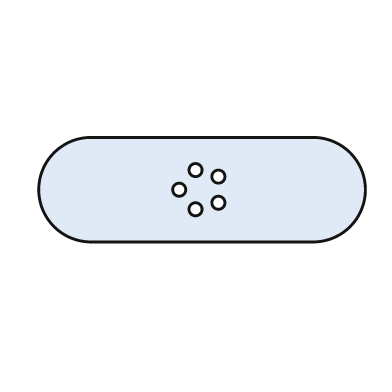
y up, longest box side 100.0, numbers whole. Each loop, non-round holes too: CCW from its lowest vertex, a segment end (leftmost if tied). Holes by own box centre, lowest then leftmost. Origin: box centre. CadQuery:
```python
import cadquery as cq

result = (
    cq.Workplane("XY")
    .moveTo(-34.0, -16.0)
    .lineTo(34.0, -16.0)
    .threePointArc((50.0, 0.0), (34.0, 16.0))
    .lineTo(-34.0, 16.0)
    .threePointArc((-50.0, 0.0), (-34.0, -16.0))
    .close()
    .moveTo(-2.0, -6.0)
    .circle(2.0)
    .moveTo(5.0, -4.0)
    .circle(2.0)
    .moveTo(-7.0, 0.0)
    .circle(2.0)
    .moveTo(5.0, 4.0)
    .circle(2.0)
    .moveTo(-2.0, 6.0)
    .circle(2.0)
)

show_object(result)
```